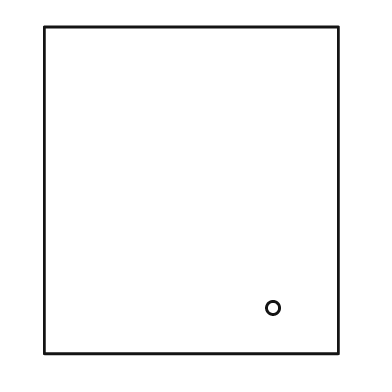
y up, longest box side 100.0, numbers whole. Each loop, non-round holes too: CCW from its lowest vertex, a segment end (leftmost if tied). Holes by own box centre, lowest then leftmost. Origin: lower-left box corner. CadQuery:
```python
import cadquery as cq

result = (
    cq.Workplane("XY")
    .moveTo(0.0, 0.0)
    .lineTo(90.0, 0.0)
    .lineTo(90.0, 100.0)
    .lineTo(0.0, 100.0)
    .close()
    .moveTo(70.0, 14.0)
    .circle(2.0)
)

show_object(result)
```